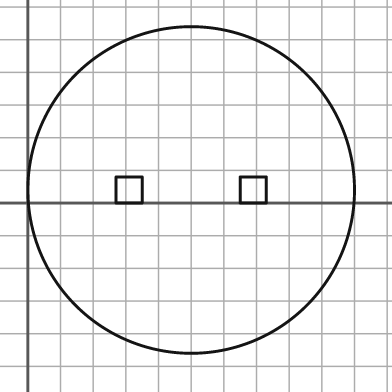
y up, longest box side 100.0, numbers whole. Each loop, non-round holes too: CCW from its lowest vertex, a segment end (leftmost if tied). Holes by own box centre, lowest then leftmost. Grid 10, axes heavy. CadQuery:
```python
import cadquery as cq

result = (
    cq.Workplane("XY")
    .moveTo(50.0, 4.0)
    .circle(50.0)
    .moveTo(27.0, 0.0)
    .lineTo(35.0, 0.0)
    .lineTo(35.0, 8.0)
    .lineTo(27.0, 8.0)
    .close()
    .moveTo(65.0, 0.0)
    .lineTo(73.0, 0.0)
    .lineTo(73.0, 8.0)
    .lineTo(65.0, 8.0)
    .close()
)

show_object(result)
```